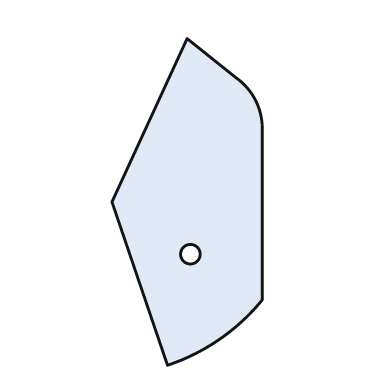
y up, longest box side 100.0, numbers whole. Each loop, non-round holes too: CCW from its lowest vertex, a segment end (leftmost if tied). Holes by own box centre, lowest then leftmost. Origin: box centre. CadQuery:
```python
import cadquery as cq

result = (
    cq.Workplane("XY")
    .moveTo(-6.0, -50.0)
    .threePointArc((10.0, -42.0), (23.0, -30.0))
    .lineTo(23.0, 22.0)
    .threePointArc((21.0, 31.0), (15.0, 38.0))
    .lineTo(0.0, 50.0)
    .lineTo(-23.0, 0.0)
    .close()
    .moveTo(1.0, -16.0)
    .circle(3.0)
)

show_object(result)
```